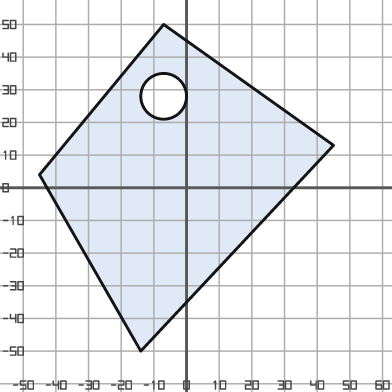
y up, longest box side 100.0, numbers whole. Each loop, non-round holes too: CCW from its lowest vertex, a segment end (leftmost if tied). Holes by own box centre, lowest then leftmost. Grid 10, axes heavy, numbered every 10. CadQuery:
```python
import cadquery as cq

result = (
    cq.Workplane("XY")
    .moveTo(-14.0, -50.0)
    .lineTo(45.0, 13.0)
    .lineTo(-7.0, 50.0)
    .lineTo(-45.0, 4.0)
    .close()
    .moveTo(-7.0, 28.0)
    .circle(7.0)
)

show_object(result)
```